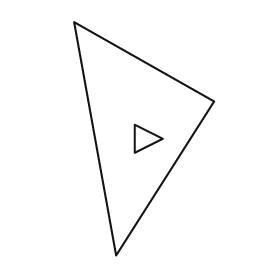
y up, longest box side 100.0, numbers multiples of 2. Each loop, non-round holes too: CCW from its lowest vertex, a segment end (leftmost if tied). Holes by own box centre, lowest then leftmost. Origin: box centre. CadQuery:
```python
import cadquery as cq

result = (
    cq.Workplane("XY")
    .moveTo(-12.0, -50.0)
    .lineTo(30.0, 16.0)
    .lineTo(-30.0, 50.0)
    .close()
    .moveTo(-4.0, -6.0)
    .lineTo(8.0, 0.0)
    .lineTo(-4.0, 6.0)
    .close()
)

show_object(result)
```